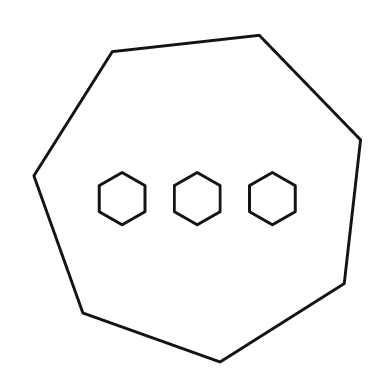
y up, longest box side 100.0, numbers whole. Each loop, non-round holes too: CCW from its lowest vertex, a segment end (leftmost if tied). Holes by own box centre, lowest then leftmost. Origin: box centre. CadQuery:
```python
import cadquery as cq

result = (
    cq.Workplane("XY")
    .moveTo(7.0, -50.0)
    .lineTo(45.0, -26.0)
    .lineTo(50.0, 18.0)
    .lineTo(19.0, 50.0)
    .lineTo(-26.0, 45.0)
    .lineTo(-50.0, 7.0)
    .lineTo(-35.0, -35.0)
    .close()
    .moveTo(-23.0, -8.0)
    .lineTo(-16.0, -4.0)
    .lineTo(-16.0, 4.0)
    .lineTo(-23.0, 8.0)
    .lineTo(-30.0, 4.0)
    .lineTo(-30.0, -4.0)
    .close()
    .moveTo(0.0, -8.0)
    .lineTo(7.0, -4.0)
    .lineTo(7.0, 4.0)
    .lineTo(0.0, 8.0)
    .lineTo(-7.0, 4.0)
    .lineTo(-7.0, -4.0)
    .close()
    .moveTo(23.0, -8.0)
    .lineTo(30.0, -4.0)
    .lineTo(30.0, 4.0)
    .lineTo(23.0, 8.0)
    .lineTo(16.0, 4.0)
    .lineTo(16.0, -4.0)
    .close()
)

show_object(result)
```